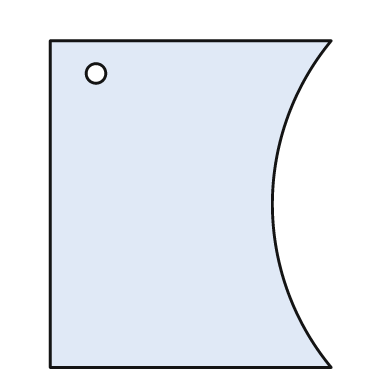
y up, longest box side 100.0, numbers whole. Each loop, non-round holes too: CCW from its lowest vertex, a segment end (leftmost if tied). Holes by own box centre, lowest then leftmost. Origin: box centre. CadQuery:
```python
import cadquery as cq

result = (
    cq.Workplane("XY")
    .moveTo(-43.0, -50.0)
    .lineTo(43.0, -50.0)
    .threePointArc((25.0, 0.0), (43.0, 50.0))
    .lineTo(-43.0, 50.0)
    .close()
    .moveTo(-29.0, 40.0)
    .circle(3.0)
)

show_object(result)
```